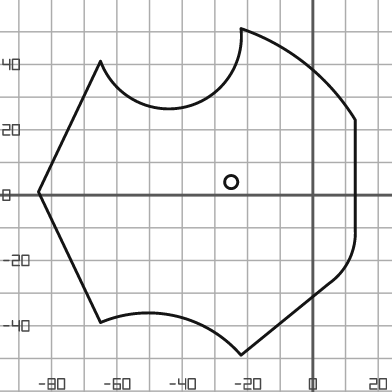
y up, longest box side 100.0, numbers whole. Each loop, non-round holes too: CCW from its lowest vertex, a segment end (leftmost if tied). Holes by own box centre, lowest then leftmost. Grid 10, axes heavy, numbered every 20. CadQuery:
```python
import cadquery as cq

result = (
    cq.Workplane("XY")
    .moveTo(-22.0, -49.0)
    .lineTo(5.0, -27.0)
    .threePointArc((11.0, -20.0), (13.0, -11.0))
    .lineTo(13.0, 23.0)
    .threePointArc((-2.0, 40.0), (-22.0, 51.0))
    .threePointArc((-39.0, 27.0), (-65.0, 41.0))
    .lineTo(-84.0, 1.0)
    .lineTo(-65.0, -39.0)
    .threePointArc((-42.0, -37.0), (-22.0, -49.0))
    .close()
    .moveTo(-25.0, 4.0)
    .circle(2.0)
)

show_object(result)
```